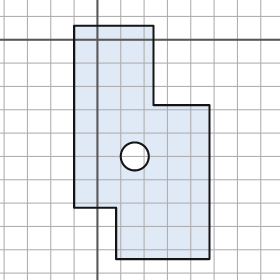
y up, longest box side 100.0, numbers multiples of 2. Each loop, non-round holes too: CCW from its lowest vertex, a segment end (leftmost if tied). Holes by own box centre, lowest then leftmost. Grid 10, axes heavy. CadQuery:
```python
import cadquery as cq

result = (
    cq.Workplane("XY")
    .moveTo(8.0, -94.0)
    .lineTo(48.0, -94.0)
    .lineTo(48.0, -28.0)
    .lineTo(24.0, -28.0)
    .lineTo(24.0, 6.0)
    .lineTo(-10.0, 6.0)
    .lineTo(-10.0, -72.0)
    .lineTo(8.0, -72.0)
    .close()
    .moveTo(16.0, -50.0)
    .circle(6.0)
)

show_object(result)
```